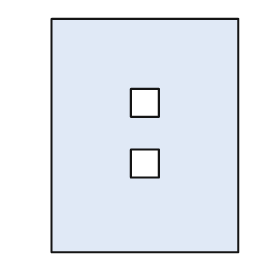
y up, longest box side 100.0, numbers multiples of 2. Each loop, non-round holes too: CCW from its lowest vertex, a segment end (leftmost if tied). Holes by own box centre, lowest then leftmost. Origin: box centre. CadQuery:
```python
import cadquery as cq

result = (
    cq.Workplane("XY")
    .moveTo(-40.0, -50.0)
    .lineTo(40.0, -50.0)
    .lineTo(40.0, 50.0)
    .lineTo(-40.0, 50.0)
    .close()
    .moveTo(-6.0, -18.0)
    .lineTo(6.0, -18.0)
    .lineTo(6.0, -6.0)
    .lineTo(-6.0, -6.0)
    .close()
    .moveTo(-6.0, 8.0)
    .lineTo(6.0, 8.0)
    .lineTo(6.0, 20.0)
    .lineTo(-6.0, 20.0)
    .close()
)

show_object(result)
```